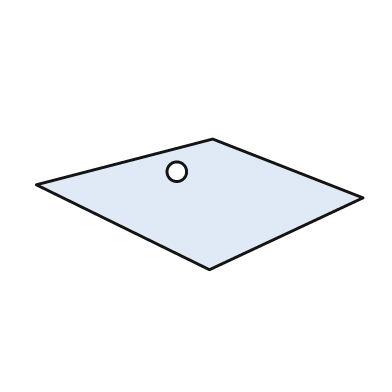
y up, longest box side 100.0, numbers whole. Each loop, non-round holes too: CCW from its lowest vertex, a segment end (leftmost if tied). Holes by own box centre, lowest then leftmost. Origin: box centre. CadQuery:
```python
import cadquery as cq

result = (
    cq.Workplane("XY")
    .moveTo(3.0, -20.0)
    .lineTo(50.0, 2.0)
    .lineTo(4.0, 20.0)
    .lineTo(-50.0, 6.0)
    .close()
    .moveTo(-7.0, 10.0)
    .circle(3.0)
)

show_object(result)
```